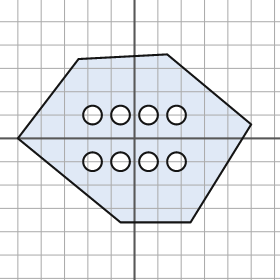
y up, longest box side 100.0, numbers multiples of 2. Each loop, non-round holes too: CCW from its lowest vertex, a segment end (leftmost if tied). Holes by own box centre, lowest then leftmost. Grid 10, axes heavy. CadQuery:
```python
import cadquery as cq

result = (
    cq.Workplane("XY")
    .moveTo(-6.0, -36.0)
    .lineTo(24.0, -36.0)
    .lineTo(50.0, 6.0)
    .lineTo(14.0, 36.0)
    .lineTo(-24.0, 34.0)
    .lineTo(-50.0, 0.0)
    .close()
    .moveTo(-18.0, -10.0)
    .circle(4.0)
    .moveTo(-6.0, -10.0)
    .circle(4.0)
    .moveTo(6.0, -10.0)
    .circle(4.0)
    .moveTo(18.0, -10.0)
    .circle(4.0)
    .moveTo(-18.0, 10.0)
    .circle(4.0)
    .moveTo(-6.0, 10.0)
    .circle(4.0)
    .moveTo(6.0, 10.0)
    .circle(4.0)
    .moveTo(18.0, 10.0)
    .circle(4.0)
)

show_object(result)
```